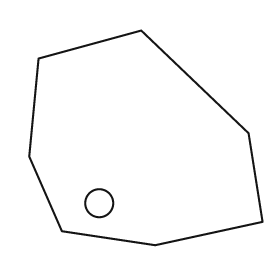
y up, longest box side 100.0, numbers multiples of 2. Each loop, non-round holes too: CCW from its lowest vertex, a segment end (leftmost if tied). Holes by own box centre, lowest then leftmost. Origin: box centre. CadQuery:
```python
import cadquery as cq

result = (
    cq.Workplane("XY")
    .moveTo(4.0, -46.0)
    .lineTo(50.0, -36.0)
    .lineTo(44.0, 2.0)
    .lineTo(-2.0, 46.0)
    .lineTo(-46.0, 34.0)
    .lineTo(-50.0, -8.0)
    .lineTo(-36.0, -40.0)
    .close()
    .moveTo(-20.0, -28.0)
    .circle(6.0)
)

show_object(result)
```